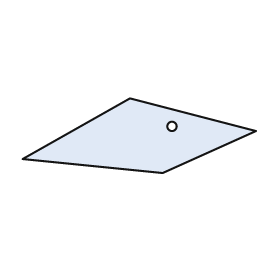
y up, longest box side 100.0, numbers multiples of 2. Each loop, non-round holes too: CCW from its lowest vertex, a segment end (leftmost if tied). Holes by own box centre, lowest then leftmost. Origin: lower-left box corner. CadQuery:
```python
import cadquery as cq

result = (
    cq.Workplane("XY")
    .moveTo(60.0, 0.0)
    .lineTo(100.0, 18.0)
    .lineTo(46.0, 32.0)
    .lineTo(0.0, 6.0)
    .close()
    .moveTo(64.0, 20.0)
    .circle(2.0)
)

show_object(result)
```